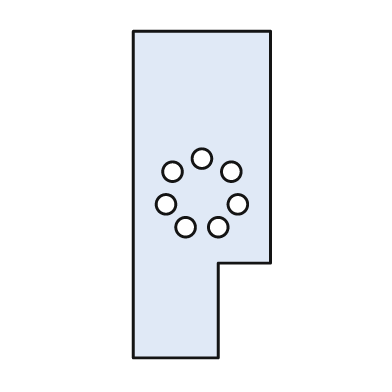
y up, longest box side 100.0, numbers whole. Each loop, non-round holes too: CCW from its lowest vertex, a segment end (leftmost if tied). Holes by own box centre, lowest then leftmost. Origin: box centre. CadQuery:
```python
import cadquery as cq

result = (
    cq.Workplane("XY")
    .moveTo(-21.0, -50.0)
    .lineTo(5.0, -50.0)
    .lineTo(5.0, -21.0)
    .lineTo(21.0, -21.0)
    .lineTo(21.0, 50.0)
    .lineTo(-21.0, 50.0)
    .close()
    .moveTo(-5.0, -10.0)
    .circle(3.0)
    .moveTo(5.0, -10.0)
    .circle(3.0)
    .moveTo(-11.0, -3.0)
    .circle(3.0)
    .moveTo(11.0, -3.0)
    .circle(3.0)
    .moveTo(-9.0, 7.0)
    .circle(3.0)
    .moveTo(9.0, 7.0)
    .circle(3.0)
    .moveTo(0.0, 11.0)
    .circle(3.0)
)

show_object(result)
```